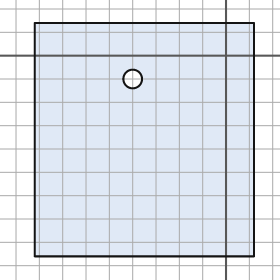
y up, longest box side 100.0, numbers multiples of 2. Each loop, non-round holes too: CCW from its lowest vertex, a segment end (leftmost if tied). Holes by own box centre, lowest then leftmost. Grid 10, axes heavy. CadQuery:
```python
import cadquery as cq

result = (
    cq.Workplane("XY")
    .moveTo(-82.0, -86.0)
    .lineTo(12.0, -86.0)
    .lineTo(12.0, 14.0)
    .lineTo(-82.0, 14.0)
    .close()
    .moveTo(-40.0, -10.0)
    .circle(4.0)
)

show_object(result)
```